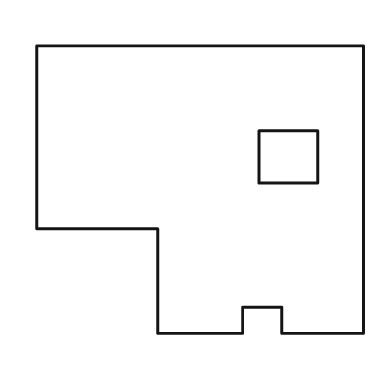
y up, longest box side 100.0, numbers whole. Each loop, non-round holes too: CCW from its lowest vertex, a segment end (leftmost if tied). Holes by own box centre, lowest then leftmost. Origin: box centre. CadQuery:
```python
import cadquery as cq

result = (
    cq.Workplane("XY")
    .moveTo(-13.0, -44.0)
    .lineTo(13.0, -44.0)
    .lineTo(13.0, -36.0)
    .lineTo(25.0, -36.0)
    .lineTo(25.0, -44.0)
    .lineTo(50.0, -44.0)
    .lineTo(50.0, 44.0)
    .lineTo(-50.0, 44.0)
    .lineTo(-50.0, -12.0)
    .lineTo(-13.0, -12.0)
    .close()
    .moveTo(18.0, 2.0)
    .lineTo(36.0, 2.0)
    .lineTo(36.0, 18.0)
    .lineTo(18.0, 18.0)
    .close()
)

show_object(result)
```